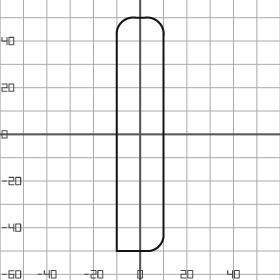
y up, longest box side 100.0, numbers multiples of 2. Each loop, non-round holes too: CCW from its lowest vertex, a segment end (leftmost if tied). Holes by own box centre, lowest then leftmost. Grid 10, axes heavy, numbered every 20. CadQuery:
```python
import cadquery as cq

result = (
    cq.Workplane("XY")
    .moveTo(-10.0, -50.0)
    .lineTo(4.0, -50.0)
    .threePointArc((8.0, -48.0), (10.0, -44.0))
    .lineTo(10.0, 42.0)
    .threePointArc((8.0, 48.0), (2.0, 50.0))
    .lineTo(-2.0, 50.0)
    .threePointArc((-8.0, 48.0), (-10.0, 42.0))
    .close()
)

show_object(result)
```